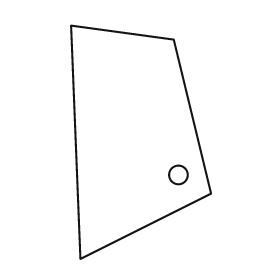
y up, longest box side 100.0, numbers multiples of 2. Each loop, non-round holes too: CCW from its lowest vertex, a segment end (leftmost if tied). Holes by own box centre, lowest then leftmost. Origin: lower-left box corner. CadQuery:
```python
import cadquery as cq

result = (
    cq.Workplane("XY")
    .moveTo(4.0, 0.0)
    .lineTo(60.0, 28.0)
    .lineTo(44.0, 94.0)
    .lineTo(0.0, 100.0)
    .close()
    .moveTo(46.0, 36.0)
    .circle(4.0)
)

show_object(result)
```